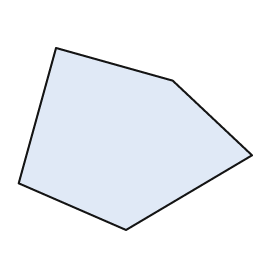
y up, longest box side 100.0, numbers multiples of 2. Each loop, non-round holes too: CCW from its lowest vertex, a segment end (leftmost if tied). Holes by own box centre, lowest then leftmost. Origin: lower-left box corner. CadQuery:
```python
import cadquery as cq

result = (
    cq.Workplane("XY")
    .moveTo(46.0, 0.0)
    .lineTo(100.0, 32.0)
    .lineTo(66.0, 64.0)
    .lineTo(16.0, 78.0)
    .lineTo(0.0, 20.0)
    .close()
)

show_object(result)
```